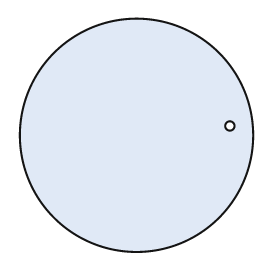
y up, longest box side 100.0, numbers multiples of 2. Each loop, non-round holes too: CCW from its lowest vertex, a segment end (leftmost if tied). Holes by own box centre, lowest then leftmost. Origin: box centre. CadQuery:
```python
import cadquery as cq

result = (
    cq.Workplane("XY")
    .moveTo(0.0, 0.0)
    .circle(50.0)
    .moveTo(40.0, 4.0)
    .circle(2.0)
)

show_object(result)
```